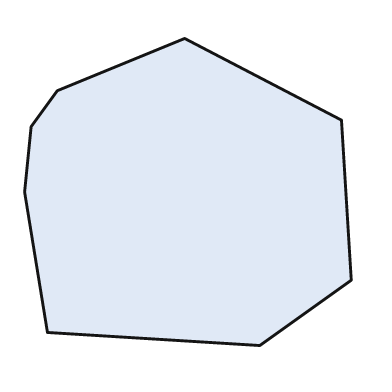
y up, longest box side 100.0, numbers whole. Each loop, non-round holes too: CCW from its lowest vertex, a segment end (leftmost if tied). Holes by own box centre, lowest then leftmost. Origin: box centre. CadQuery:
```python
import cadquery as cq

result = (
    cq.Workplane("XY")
    .moveTo(22.0, -47.0)
    .lineTo(50.0, -27.0)
    .lineTo(47.0, 22.0)
    .lineTo(-1.0, 47.0)
    .lineTo(-40.0, 31.0)
    .lineTo(-48.0, 20.0)
    .lineTo(-50.0, 0.0)
    .lineTo(-43.0, -43.0)
    .close()
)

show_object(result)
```